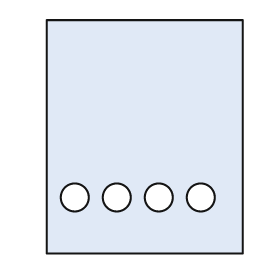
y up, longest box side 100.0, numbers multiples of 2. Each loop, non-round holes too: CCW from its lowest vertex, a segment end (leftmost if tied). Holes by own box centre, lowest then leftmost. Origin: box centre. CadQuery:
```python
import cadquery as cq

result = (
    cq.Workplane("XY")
    .moveTo(-42.0, -50.0)
    .lineTo(42.0, -50.0)
    .lineTo(42.0, 50.0)
    .lineTo(-42.0, 50.0)
    .close()
    .moveTo(-30.0, -26.0)
    .circle(6.0)
    .moveTo(-12.0, -26.0)
    .circle(6.0)
    .moveTo(6.0, -26.0)
    .circle(6.0)
    .moveTo(24.0, -26.0)
    .circle(6.0)
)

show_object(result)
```